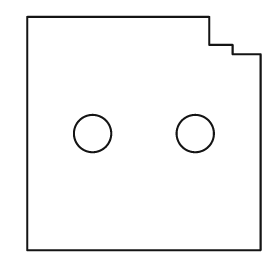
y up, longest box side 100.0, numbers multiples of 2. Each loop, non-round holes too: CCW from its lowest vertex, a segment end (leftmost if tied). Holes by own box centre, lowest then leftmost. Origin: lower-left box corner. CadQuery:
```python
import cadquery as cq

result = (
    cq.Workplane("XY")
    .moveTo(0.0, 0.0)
    .lineTo(100.0, 0.0)
    .lineTo(100.0, 84.0)
    .lineTo(88.0, 84.0)
    .lineTo(88.0, 88.0)
    .lineTo(78.0, 88.0)
    .lineTo(78.0, 100.0)
    .lineTo(0.0, 100.0)
    .close()
    .moveTo(28.0, 50.0)
    .circle(8.0)
    .moveTo(72.0, 50.0)
    .circle(8.0)
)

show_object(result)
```